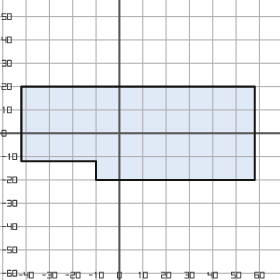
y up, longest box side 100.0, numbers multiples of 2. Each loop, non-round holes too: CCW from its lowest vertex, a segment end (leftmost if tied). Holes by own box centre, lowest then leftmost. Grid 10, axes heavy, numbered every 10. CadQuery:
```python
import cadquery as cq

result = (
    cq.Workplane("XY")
    .moveTo(-10.0, -20.0)
    .lineTo(58.0, -20.0)
    .lineTo(58.0, 20.0)
    .lineTo(-42.0, 20.0)
    .lineTo(-42.0, -12.0)
    .lineTo(-10.0, -12.0)
    .close()
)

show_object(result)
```